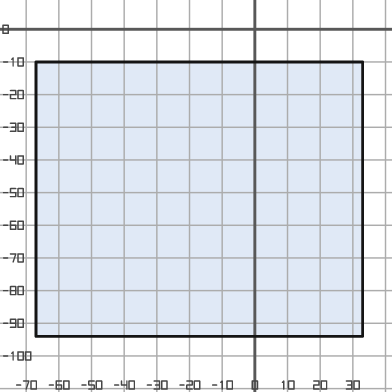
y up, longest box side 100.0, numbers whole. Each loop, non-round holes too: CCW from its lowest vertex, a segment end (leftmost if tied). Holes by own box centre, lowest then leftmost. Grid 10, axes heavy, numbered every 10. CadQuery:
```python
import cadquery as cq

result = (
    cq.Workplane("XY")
    .moveTo(-67.0, -94.0)
    .lineTo(33.0, -94.0)
    .lineTo(33.0, -10.0)
    .lineTo(-67.0, -10.0)
    .close()
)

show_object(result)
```